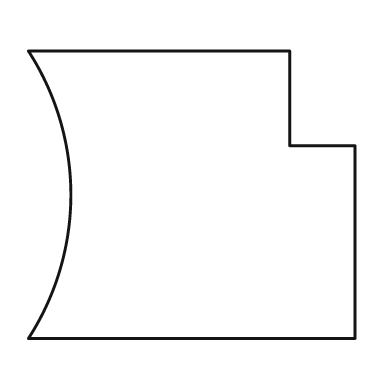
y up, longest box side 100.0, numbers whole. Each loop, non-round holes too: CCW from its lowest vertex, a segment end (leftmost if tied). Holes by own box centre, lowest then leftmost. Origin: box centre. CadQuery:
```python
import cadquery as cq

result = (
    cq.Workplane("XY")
    .moveTo(-50.0, -44.0)
    .lineTo(50.0, -44.0)
    .lineTo(50.0, 15.0)
    .lineTo(30.0, 15.0)
    .lineTo(30.0, 44.0)
    .lineTo(-50.0, 44.0)
    .threePointArc((-37.0, 0.0), (-50.0, -44.0))
    .close()
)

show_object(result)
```